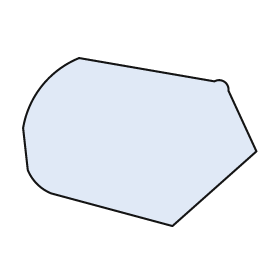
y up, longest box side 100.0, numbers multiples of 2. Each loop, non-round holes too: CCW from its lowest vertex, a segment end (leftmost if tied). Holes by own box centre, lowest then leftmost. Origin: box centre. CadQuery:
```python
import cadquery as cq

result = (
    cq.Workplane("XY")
    .moveTo(14.0, -36.0)
    .lineTo(50.0, -4.0)
    .lineTo(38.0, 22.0)
    .threePointArc((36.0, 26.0), (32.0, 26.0))
    .lineTo(-26.0, 36.0)
    .threePointArc((-42.0, 24.0), (-50.0, 6.0))
    .lineTo(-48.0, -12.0)
    .threePointArc((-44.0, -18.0), (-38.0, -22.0))
    .close()
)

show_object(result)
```